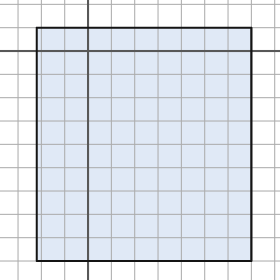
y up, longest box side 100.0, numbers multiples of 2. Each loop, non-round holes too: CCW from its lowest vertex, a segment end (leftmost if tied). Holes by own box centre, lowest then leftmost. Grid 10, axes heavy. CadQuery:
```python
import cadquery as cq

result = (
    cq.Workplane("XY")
    .moveTo(-22.0, -90.0)
    .lineTo(70.0, -90.0)
    .lineTo(70.0, 10.0)
    .lineTo(-22.0, 10.0)
    .close()
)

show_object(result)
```